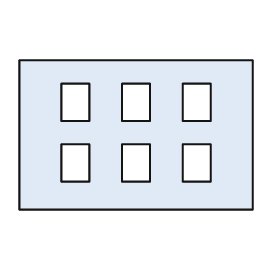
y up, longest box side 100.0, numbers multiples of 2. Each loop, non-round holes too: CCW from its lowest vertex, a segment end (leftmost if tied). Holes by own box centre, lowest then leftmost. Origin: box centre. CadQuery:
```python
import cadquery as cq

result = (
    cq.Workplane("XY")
    .moveTo(-50.0, -32.0)
    .lineTo(50.0, -32.0)
    .lineTo(50.0, 32.0)
    .lineTo(-50.0, 32.0)
    .close()
    .moveTo(-32.0, -20.0)
    .lineTo(-20.0, -20.0)
    .lineTo(-20.0, -4.0)
    .lineTo(-32.0, -4.0)
    .close()
    .moveTo(-6.0, -20.0)
    .lineTo(6.0, -20.0)
    .lineTo(6.0, -4.0)
    .lineTo(-6.0, -4.0)
    .close()
    .moveTo(20.0, -20.0)
    .lineTo(32.0, -20.0)
    .lineTo(32.0, -4.0)
    .lineTo(20.0, -4.0)
    .close()
    .moveTo(-32.0, 6.0)
    .lineTo(-20.0, 6.0)
    .lineTo(-20.0, 22.0)
    .lineTo(-32.0, 22.0)
    .close()
    .moveTo(-6.0, 6.0)
    .lineTo(6.0, 6.0)
    .lineTo(6.0, 22.0)
    .lineTo(-6.0, 22.0)
    .close()
    .moveTo(20.0, 6.0)
    .lineTo(32.0, 6.0)
    .lineTo(32.0, 22.0)
    .lineTo(20.0, 22.0)
    .close()
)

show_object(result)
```